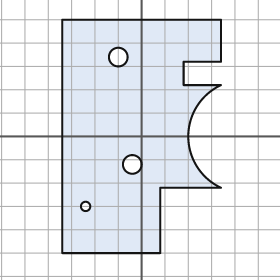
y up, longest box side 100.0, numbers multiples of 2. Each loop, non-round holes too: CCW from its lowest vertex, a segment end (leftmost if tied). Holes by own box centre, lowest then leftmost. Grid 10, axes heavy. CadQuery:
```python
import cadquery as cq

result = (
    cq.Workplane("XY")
    .moveTo(-34.0, -50.0)
    .lineTo(8.0, -50.0)
    .lineTo(8.0, -22.0)
    .lineTo(34.0, -22.0)
    .threePointArc((20.0, 0.0), (34.0, 22.0))
    .lineTo(18.0, 22.0)
    .lineTo(18.0, 32.0)
    .lineTo(34.0, 32.0)
    .lineTo(34.0, 50.0)
    .lineTo(-34.0, 50.0)
    .close()
    .moveTo(-24.0, -30.0)
    .circle(2.0)
    .moveTo(-4.0, -12.0)
    .circle(4.0)
    .moveTo(-10.0, 34.0)
    .circle(4.0)
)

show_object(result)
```